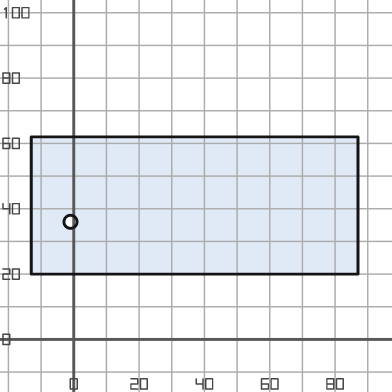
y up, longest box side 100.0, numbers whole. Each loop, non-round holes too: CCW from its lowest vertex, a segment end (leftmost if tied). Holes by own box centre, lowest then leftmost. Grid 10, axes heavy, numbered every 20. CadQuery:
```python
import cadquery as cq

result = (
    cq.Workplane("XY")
    .moveTo(-13.0, 20.0)
    .lineTo(87.0, 20.0)
    .lineTo(87.0, 62.0)
    .lineTo(-13.0, 62.0)
    .close()
    .moveTo(-1.0, 36.0)
    .circle(2.0)
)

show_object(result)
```